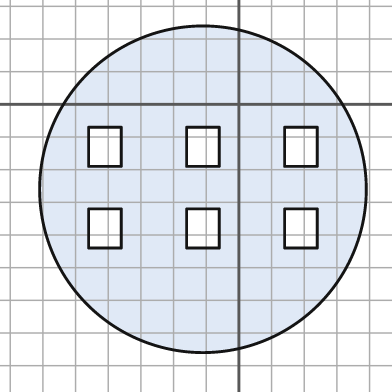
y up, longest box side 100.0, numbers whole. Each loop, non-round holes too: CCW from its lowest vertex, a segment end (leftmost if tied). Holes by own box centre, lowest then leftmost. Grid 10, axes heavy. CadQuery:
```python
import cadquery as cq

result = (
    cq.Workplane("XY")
    .moveTo(-11.0, -26.0)
    .circle(50.0)
    .moveTo(-46.0, -44.0)
    .lineTo(-36.0, -44.0)
    .lineTo(-36.0, -32.0)
    .lineTo(-46.0, -32.0)
    .close()
    .moveTo(-16.0, -44.0)
    .lineTo(-6.0, -44.0)
    .lineTo(-6.0, -32.0)
    .lineTo(-16.0, -32.0)
    .close()
    .moveTo(14.0, -44.0)
    .lineTo(24.0, -44.0)
    .lineTo(24.0, -32.0)
    .lineTo(14.0, -32.0)
    .close()
    .moveTo(-46.0, -19.0)
    .lineTo(-36.0, -19.0)
    .lineTo(-36.0, -7.0)
    .lineTo(-46.0, -7.0)
    .close()
    .moveTo(-16.0, -19.0)
    .lineTo(-6.0, -19.0)
    .lineTo(-6.0, -7.0)
    .lineTo(-16.0, -7.0)
    .close()
    .moveTo(14.0, -19.0)
    .lineTo(24.0, -19.0)
    .lineTo(24.0, -7.0)
    .lineTo(14.0, -7.0)
    .close()
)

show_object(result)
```